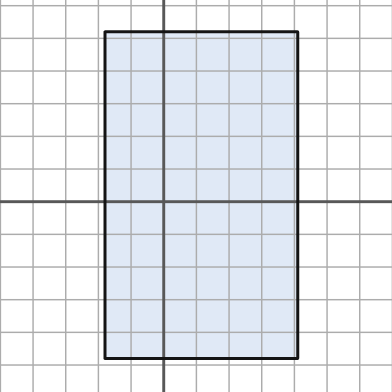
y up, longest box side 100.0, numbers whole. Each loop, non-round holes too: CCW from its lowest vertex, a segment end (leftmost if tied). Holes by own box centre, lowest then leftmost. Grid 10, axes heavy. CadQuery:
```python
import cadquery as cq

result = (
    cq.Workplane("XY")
    .moveTo(-18.0, -48.0)
    .lineTo(41.0, -48.0)
    .lineTo(41.0, 52.0)
    .lineTo(-18.0, 52.0)
    .close()
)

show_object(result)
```